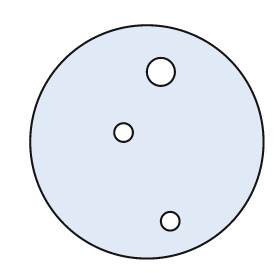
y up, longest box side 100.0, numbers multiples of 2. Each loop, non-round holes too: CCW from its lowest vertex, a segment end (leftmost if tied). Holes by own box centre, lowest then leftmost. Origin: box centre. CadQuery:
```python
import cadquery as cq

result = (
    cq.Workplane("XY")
    .moveTo(0.0, 0.0)
    .circle(50.0)
    .moveTo(10.0, -34.0)
    .circle(4.0)
    .moveTo(-10.0, 4.0)
    .circle(4.0)
    .moveTo(6.0, 30.0)
    .circle(6.0)
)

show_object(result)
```